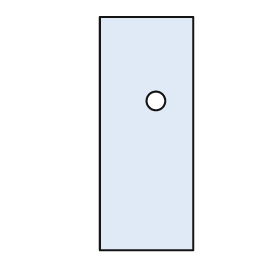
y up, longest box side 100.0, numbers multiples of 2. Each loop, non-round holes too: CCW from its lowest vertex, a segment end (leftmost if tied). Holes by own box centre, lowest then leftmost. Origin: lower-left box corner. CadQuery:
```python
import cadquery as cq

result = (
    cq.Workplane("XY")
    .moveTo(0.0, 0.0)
    .lineTo(40.0, 0.0)
    .lineTo(40.0, 100.0)
    .lineTo(0.0, 100.0)
    .close()
    .moveTo(24.0, 64.0)
    .circle(4.0)
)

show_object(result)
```